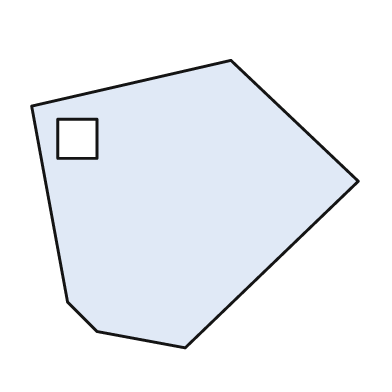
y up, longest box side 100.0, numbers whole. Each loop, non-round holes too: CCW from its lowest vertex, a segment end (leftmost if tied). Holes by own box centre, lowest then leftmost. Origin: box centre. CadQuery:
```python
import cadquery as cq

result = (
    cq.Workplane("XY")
    .moveTo(-3.0, -44.0)
    .lineTo(50.0, 7.0)
    .lineTo(11.0, 44.0)
    .lineTo(-50.0, 30.0)
    .lineTo(-39.0, -30.0)
    .lineTo(-30.0, -39.0)
    .close()
    .moveTo(-42.0, 14.0)
    .lineTo(-30.0, 14.0)
    .lineTo(-30.0, 26.0)
    .lineTo(-42.0, 26.0)
    .close()
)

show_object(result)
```